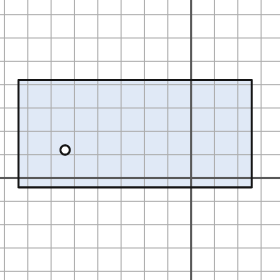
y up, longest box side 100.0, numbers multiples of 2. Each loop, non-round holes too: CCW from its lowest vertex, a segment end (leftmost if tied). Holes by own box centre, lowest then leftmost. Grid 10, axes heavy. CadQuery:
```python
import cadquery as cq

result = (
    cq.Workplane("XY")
    .moveTo(-74.0, -4.0)
    .lineTo(26.0, -4.0)
    .lineTo(26.0, 42.0)
    .lineTo(-74.0, 42.0)
    .close()
    .moveTo(-54.0, 12.0)
    .circle(2.0)
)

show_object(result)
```